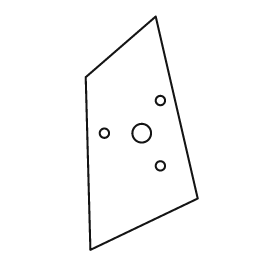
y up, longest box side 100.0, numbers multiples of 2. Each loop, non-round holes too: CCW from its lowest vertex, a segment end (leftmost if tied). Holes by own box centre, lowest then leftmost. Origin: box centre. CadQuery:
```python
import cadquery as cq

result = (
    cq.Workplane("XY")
    .moveTo(-22.0, -50.0)
    .lineTo(24.0, -28.0)
    .lineTo(6.0, 50.0)
    .lineTo(-24.0, 24.0)
    .close()
    .moveTo(8.0, -14.0)
    .circle(2.0)
    .moveTo(-16.0, 0.0)
    .circle(2.0)
    .moveTo(0.0, 0.0)
    .circle(4.0)
    .moveTo(8.0, 14.0)
    .circle(2.0)
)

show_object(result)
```